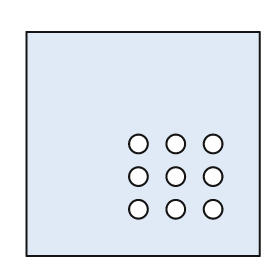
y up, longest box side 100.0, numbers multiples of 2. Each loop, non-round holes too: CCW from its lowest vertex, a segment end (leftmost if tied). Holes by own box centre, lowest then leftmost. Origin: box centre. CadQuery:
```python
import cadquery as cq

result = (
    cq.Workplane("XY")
    .moveTo(-50.0, -48.0)
    .lineTo(50.0, -48.0)
    .lineTo(50.0, 48.0)
    .lineTo(-50.0, 48.0)
    .close()
    .moveTo(-2.0, -28.0)
    .circle(4.0)
    .moveTo(14.0, -28.0)
    .circle(4.0)
    .moveTo(30.0, -28.0)
    .circle(4.0)
    .moveTo(-2.0, -14.0)
    .circle(4.0)
    .moveTo(14.0, -14.0)
    .circle(4.0)
    .moveTo(30.0, -14.0)
    .circle(4.0)
    .moveTo(-2.0, 0.0)
    .circle(4.0)
    .moveTo(14.0, 0.0)
    .circle(4.0)
    .moveTo(30.0, 0.0)
    .circle(4.0)
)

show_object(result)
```